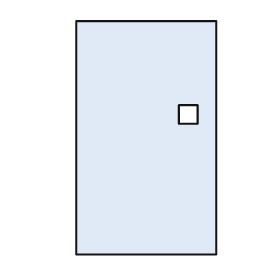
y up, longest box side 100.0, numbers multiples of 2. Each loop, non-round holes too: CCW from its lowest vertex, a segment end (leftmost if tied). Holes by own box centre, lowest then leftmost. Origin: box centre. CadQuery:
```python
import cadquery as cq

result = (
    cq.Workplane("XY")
    .moveTo(-30.0, -50.0)
    .lineTo(30.0, -50.0)
    .lineTo(30.0, 50.0)
    .lineTo(-30.0, 50.0)
    .close()
    .moveTo(14.0, 6.0)
    .lineTo(22.0, 6.0)
    .lineTo(22.0, 14.0)
    .lineTo(14.0, 14.0)
    .close()
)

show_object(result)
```